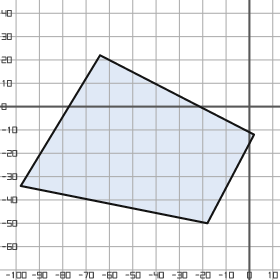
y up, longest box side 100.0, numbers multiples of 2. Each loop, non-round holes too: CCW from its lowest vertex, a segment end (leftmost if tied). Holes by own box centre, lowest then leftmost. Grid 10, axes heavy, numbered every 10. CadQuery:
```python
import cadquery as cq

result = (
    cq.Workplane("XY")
    .moveTo(-18.0, -50.0)
    .lineTo(2.0, -12.0)
    .lineTo(-64.0, 22.0)
    .lineTo(-98.0, -34.0)
    .close()
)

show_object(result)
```